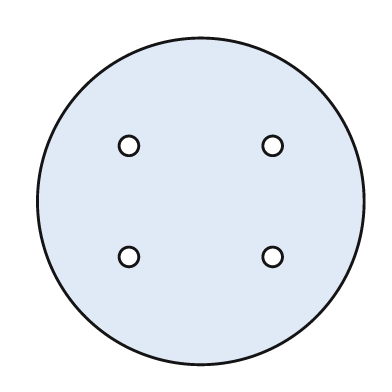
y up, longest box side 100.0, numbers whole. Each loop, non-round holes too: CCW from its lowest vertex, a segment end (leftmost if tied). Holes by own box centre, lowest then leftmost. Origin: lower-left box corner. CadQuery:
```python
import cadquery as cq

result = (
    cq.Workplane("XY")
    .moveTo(50.0, 50.0)
    .circle(50.0)
    .moveTo(28.0, 33.0)
    .circle(3.0)
    .moveTo(72.0, 33.0)
    .circle(3.0)
    .moveTo(28.0, 67.0)
    .circle(3.0)
    .moveTo(72.0, 67.0)
    .circle(3.0)
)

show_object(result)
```